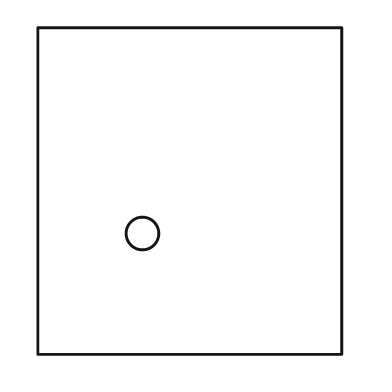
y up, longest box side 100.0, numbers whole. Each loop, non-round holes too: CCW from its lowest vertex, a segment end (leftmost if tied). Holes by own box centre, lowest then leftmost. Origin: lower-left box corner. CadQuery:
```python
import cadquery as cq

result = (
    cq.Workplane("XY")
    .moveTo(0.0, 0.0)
    .lineTo(93.0, 0.0)
    .lineTo(93.0, 100.0)
    .lineTo(0.0, 100.0)
    .close()
    .moveTo(32.0, 37.0)
    .circle(5.0)
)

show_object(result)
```